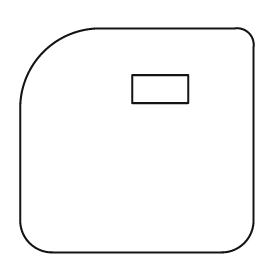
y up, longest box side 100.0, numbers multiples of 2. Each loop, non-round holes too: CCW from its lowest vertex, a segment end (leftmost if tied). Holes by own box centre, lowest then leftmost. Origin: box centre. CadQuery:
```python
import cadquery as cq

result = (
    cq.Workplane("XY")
    .moveTo(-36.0, -48.0)
    .lineTo(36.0, -48.0)
    .threePointArc((46.0, -44.0), (50.0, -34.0))
    .lineTo(50.0, 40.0)
    .threePointArc((48.0, 46.0), (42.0, 48.0))
    .lineTo(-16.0, 48.0)
    .threePointArc((-40.0, 38.0), (-50.0, 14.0))
    .lineTo(-50.0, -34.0)
    .threePointArc((-46.0, -44.0), (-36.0, -48.0))
    .close()
    .moveTo(-2.0, 16.0)
    .lineTo(22.0, 16.0)
    .lineTo(22.0, 28.0)
    .lineTo(-2.0, 28.0)
    .close()
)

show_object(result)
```